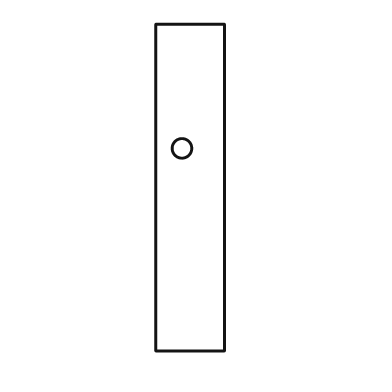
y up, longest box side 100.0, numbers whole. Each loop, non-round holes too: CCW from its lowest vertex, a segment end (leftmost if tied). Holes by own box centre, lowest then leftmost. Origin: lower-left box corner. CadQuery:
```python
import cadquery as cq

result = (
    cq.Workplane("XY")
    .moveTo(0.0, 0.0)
    .lineTo(21.0, 0.0)
    .lineTo(21.0, 100.0)
    .lineTo(0.0, 100.0)
    .close()
    .moveTo(8.0, 62.0)
    .circle(3.0)
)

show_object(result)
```